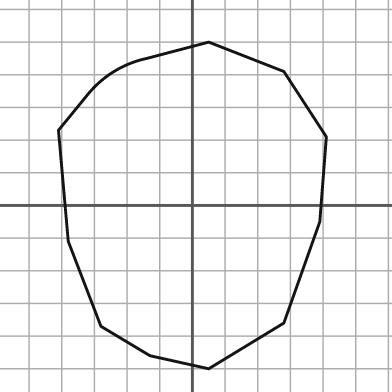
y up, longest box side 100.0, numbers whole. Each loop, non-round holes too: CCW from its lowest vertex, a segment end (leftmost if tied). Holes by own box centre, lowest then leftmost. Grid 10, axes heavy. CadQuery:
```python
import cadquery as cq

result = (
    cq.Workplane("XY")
    .moveTo(5.0, -50.0)
    .lineTo(28.0, -36.0)
    .lineTo(39.0, -5.0)
    .lineTo(41.0, 21.0)
    .lineTo(28.0, 41.0)
    .lineTo(5.0, 50.0)
    .lineTo(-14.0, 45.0)
    .threePointArc((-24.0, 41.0), (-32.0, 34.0))
    .lineTo(-41.0, 23.0)
    .lineTo(-38.0, -11.0)
    .lineTo(-28.0, -37.0)
    .lineTo(-13.0, -46.0)
    .close()
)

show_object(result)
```